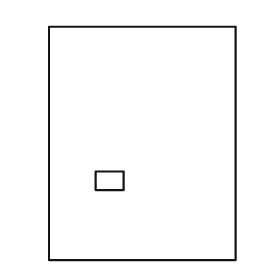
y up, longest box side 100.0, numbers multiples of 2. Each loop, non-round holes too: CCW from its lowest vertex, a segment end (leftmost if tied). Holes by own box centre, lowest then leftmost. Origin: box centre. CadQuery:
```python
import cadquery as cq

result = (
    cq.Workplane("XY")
    .moveTo(-40.0, -50.0)
    .lineTo(40.0, -50.0)
    .lineTo(40.0, 50.0)
    .lineTo(-40.0, 50.0)
    .close()
    .moveTo(-20.0, -20.0)
    .lineTo(-8.0, -20.0)
    .lineTo(-8.0, -12.0)
    .lineTo(-20.0, -12.0)
    .close()
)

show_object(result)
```